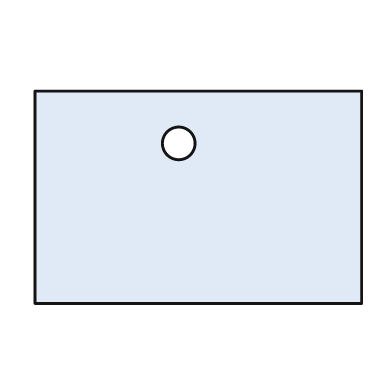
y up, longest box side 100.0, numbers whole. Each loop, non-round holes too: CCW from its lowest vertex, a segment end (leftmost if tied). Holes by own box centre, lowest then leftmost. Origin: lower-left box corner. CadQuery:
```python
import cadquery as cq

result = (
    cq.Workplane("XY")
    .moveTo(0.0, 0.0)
    .lineTo(100.0, 0.0)
    .lineTo(100.0, 65.0)
    .lineTo(0.0, 65.0)
    .close()
    .moveTo(44.0, 49.0)
    .circle(5.0)
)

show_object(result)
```